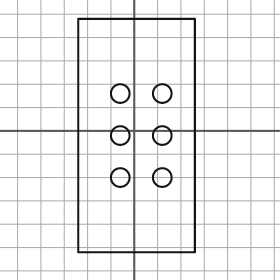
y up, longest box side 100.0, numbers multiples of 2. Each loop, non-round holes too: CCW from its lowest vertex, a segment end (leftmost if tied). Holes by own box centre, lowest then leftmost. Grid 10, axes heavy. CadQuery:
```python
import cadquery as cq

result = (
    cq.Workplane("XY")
    .moveTo(-24.0, -52.0)
    .lineTo(26.0, -52.0)
    .lineTo(26.0, 48.0)
    .lineTo(-24.0, 48.0)
    .close()
    .moveTo(-6.0, -20.0)
    .circle(4.0)
    .moveTo(12.0, -20.0)
    .circle(4.0)
    .moveTo(-6.0, -2.0)
    .circle(4.0)
    .moveTo(12.0, -2.0)
    .circle(4.0)
    .moveTo(-6.0, 16.0)
    .circle(4.0)
    .moveTo(12.0, 16.0)
    .circle(4.0)
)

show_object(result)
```